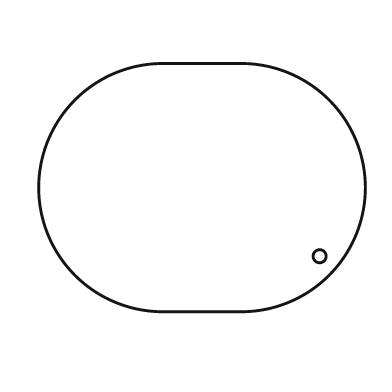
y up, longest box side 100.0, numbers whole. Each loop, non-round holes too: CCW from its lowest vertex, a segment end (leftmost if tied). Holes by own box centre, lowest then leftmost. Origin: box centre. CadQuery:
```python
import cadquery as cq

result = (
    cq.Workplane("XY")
    .moveTo(-12.0, -38.0)
    .lineTo(12.0, -38.0)
    .threePointArc((50.0, 0.0), (12.0, 38.0))
    .lineTo(-12.0, 38.0)
    .threePointArc((-50.0, 0.0), (-12.0, -38.0))
    .close()
    .moveTo(36.0, -21.0)
    .circle(2.0)
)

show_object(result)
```